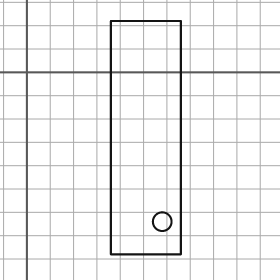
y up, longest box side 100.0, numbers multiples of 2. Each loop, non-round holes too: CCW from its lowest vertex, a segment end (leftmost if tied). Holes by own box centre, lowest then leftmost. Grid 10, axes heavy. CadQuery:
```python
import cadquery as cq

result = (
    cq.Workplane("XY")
    .moveTo(36.0, -78.0)
    .lineTo(66.0, -78.0)
    .lineTo(66.0, 22.0)
    .lineTo(36.0, 22.0)
    .close()
    .moveTo(58.0, -64.0)
    .circle(4.0)
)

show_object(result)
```